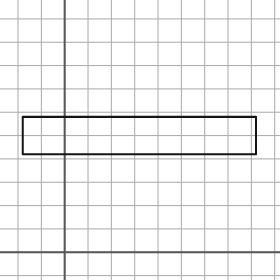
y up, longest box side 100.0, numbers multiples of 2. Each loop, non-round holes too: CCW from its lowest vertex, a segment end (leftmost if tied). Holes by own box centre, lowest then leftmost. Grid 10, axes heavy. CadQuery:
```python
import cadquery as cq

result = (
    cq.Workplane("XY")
    .moveTo(-18.0, 42.0)
    .lineTo(82.0, 42.0)
    .lineTo(82.0, 58.0)
    .lineTo(-18.0, 58.0)
    .close()
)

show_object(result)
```